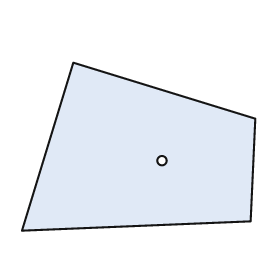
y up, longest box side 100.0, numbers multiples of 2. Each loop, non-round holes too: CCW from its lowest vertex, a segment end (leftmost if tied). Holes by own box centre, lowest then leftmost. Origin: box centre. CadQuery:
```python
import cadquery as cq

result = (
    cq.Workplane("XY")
    .moveTo(-50.0, -36.0)
    .lineTo(48.0, -32.0)
    .lineTo(50.0, 12.0)
    .lineTo(-28.0, 36.0)
    .close()
    .moveTo(10.0, -6.0)
    .circle(2.0)
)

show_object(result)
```